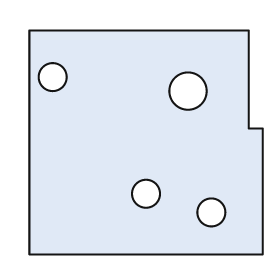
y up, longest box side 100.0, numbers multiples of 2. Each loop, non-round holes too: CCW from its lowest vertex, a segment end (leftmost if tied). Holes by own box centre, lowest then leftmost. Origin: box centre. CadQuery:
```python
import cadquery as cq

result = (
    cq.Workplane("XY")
    .moveTo(-50.0, -48.0)
    .lineTo(50.0, -48.0)
    .lineTo(50.0, 6.0)
    .lineTo(44.0, 6.0)
    .lineTo(44.0, 48.0)
    .lineTo(-50.0, 48.0)
    .close()
    .moveTo(28.0, -30.0)
    .circle(6.0)
    .moveTo(0.0, -22.0)
    .circle(6.0)
    .moveTo(18.0, 22.0)
    .circle(8.0)
    .moveTo(-40.0, 28.0)
    .circle(6.0)
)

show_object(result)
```